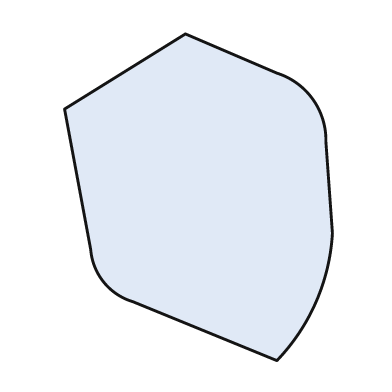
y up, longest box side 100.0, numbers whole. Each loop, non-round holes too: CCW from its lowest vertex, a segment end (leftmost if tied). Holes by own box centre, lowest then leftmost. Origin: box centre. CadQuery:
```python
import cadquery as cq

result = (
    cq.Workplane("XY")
    .moveTo(24.0, -50.0)
    .threePointArc((36.0, -32.0), (41.0, -11.0))
    .lineTo(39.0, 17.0)
    .threePointArc((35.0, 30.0), (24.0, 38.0))
    .lineTo(-4.0, 50.0)
    .lineTo(-41.0, 27.0)
    .lineTo(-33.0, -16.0)
    .threePointArc((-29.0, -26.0), (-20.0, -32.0))
    .close()
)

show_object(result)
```